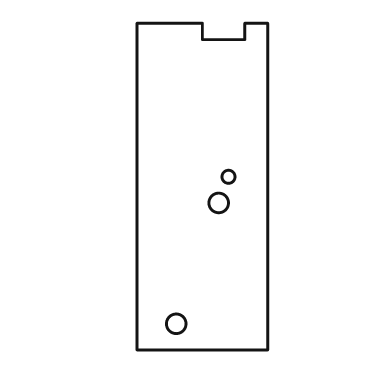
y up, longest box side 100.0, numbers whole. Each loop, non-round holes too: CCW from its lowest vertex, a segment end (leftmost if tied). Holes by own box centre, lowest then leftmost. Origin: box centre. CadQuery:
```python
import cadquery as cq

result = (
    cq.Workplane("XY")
    .moveTo(-20.0, -50.0)
    .lineTo(20.0, -50.0)
    .lineTo(20.0, 50.0)
    .lineTo(13.0, 50.0)
    .lineTo(13.0, 45.0)
    .lineTo(0.0, 45.0)
    .lineTo(0.0, 50.0)
    .lineTo(-20.0, 50.0)
    .close()
    .moveTo(-8.0, -42.0)
    .circle(3.0)
    .moveTo(5.0, -5.0)
    .circle(3.0)
    .moveTo(8.0, 3.0)
    .circle(2.0)
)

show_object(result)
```